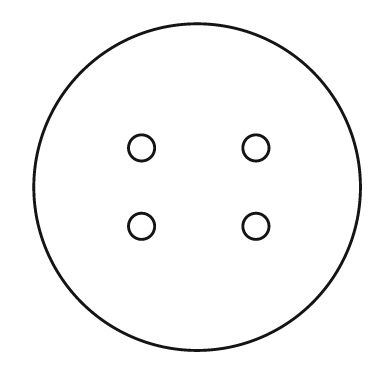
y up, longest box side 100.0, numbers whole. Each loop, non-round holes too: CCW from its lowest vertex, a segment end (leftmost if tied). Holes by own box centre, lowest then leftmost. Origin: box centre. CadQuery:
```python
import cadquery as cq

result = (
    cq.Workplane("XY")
    .moveTo(0.0, 0.0)
    .circle(50.0)
    .moveTo(-17.0, -12.0)
    .circle(4.0)
    .moveTo(18.0, -12.0)
    .circle(4.0)
    .moveTo(-17.0, 12.0)
    .circle(4.0)
    .moveTo(18.0, 12.0)
    .circle(4.0)
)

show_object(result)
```